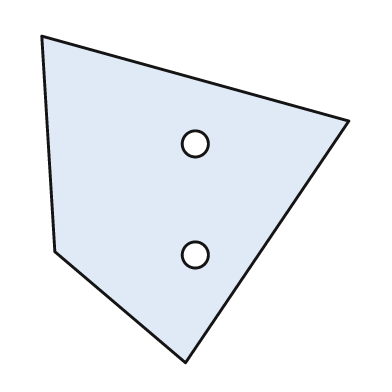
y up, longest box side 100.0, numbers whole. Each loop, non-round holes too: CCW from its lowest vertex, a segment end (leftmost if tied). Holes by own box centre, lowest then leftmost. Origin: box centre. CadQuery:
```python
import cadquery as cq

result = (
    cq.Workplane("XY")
    .moveTo(-3.0, -50.0)
    .lineTo(47.0, 24.0)
    .lineTo(-47.0, 50.0)
    .lineTo(-43.0, -16.0)
    .close()
    .moveTo(0.0, -17.0)
    .circle(4.0)
    .moveTo(0.0, 17.0)
    .circle(4.0)
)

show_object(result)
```